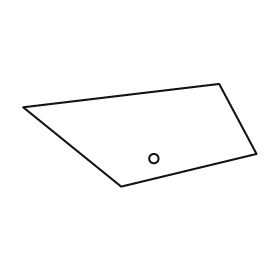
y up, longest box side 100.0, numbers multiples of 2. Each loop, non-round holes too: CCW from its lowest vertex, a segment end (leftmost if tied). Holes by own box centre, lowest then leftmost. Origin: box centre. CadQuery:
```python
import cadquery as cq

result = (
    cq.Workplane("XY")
    .moveTo(-8.0, -22.0)
    .lineTo(50.0, -8.0)
    .lineTo(34.0, 22.0)
    .lineTo(-50.0, 12.0)
    .close()
    .moveTo(6.0, -10.0)
    .circle(2.0)
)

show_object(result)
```